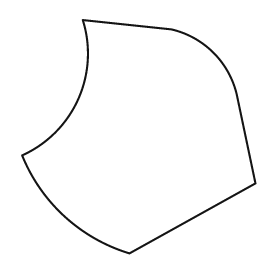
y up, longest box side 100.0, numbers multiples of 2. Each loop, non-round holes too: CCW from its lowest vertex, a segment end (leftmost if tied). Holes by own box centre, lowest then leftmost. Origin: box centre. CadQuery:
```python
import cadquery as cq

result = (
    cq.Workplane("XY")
    .moveTo(-4.0, -50.0)
    .lineTo(50.0, -20.0)
    .lineTo(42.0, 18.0)
    .threePointArc((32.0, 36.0), (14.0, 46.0))
    .lineTo(-24.0, 50.0)
    .threePointArc((-26.0, 16.0), (-50.0, -8.0))
    .threePointArc((-32.0, -34.0), (-4.0, -50.0))
    .close()
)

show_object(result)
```